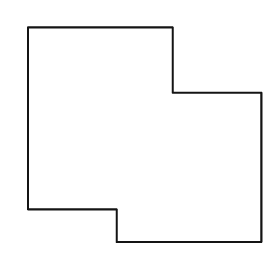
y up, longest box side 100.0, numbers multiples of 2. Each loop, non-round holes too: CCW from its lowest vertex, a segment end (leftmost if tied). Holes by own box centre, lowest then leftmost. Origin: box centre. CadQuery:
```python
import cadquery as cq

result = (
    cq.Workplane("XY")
    .moveTo(-12.0, -46.0)
    .lineTo(50.0, -46.0)
    .lineTo(50.0, 18.0)
    .lineTo(12.0, 18.0)
    .lineTo(12.0, 46.0)
    .lineTo(-50.0, 46.0)
    .lineTo(-50.0, -32.0)
    .lineTo(-12.0, -32.0)
    .close()
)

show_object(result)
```